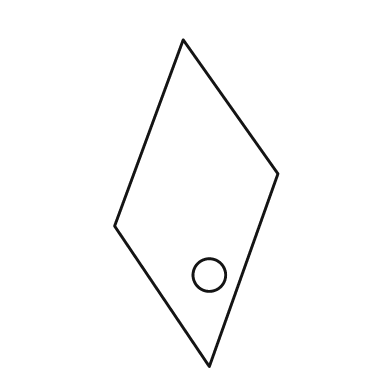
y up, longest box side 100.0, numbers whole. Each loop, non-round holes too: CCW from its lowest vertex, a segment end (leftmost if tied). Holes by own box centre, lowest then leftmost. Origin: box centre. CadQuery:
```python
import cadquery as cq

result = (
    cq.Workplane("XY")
    .moveTo(4.0, -50.0)
    .lineTo(25.0, 9.0)
    .lineTo(-4.0, 50.0)
    .lineTo(-25.0, -7.0)
    .close()
    .moveTo(4.0, -22.0)
    .circle(5.0)
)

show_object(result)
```